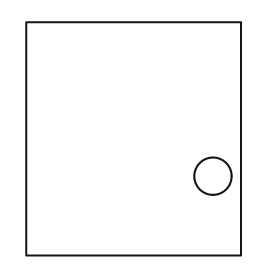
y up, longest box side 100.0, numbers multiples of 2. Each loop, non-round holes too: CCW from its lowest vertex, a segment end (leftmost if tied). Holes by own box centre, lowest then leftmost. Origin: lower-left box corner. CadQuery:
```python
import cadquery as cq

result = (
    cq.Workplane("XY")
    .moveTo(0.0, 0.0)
    .lineTo(92.0, 0.0)
    .lineTo(92.0, 100.0)
    .lineTo(0.0, 100.0)
    .close()
    .moveTo(80.0, 34.0)
    .circle(8.0)
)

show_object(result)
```